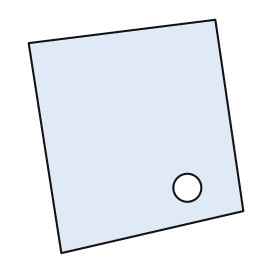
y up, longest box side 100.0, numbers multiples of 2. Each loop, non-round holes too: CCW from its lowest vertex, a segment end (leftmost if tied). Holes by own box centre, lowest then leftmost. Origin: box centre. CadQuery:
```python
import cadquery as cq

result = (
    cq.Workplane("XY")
    .moveTo(-32.0, -50.0)
    .lineTo(46.0, -32.0)
    .lineTo(34.0, 50.0)
    .lineTo(-46.0, 40.0)
    .close()
    .moveTo(22.0, -22.0)
    .circle(6.0)
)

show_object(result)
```